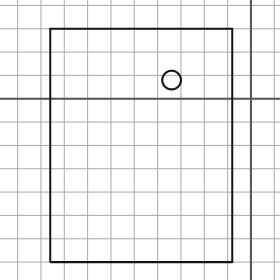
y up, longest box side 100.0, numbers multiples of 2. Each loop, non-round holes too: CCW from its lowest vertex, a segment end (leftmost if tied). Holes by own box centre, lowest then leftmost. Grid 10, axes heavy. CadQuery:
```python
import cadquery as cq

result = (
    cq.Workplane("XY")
    .moveTo(-86.0, -70.0)
    .lineTo(-8.0, -70.0)
    .lineTo(-8.0, 30.0)
    .lineTo(-86.0, 30.0)
    .close()
    .moveTo(-34.0, 8.0)
    .circle(4.0)
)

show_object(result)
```